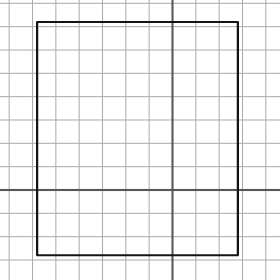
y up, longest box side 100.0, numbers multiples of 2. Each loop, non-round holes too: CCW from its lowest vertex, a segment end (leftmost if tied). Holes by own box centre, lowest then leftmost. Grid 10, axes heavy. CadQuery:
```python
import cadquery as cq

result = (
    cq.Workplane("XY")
    .moveTo(-58.0, -28.0)
    .lineTo(28.0, -28.0)
    .lineTo(28.0, 72.0)
    .lineTo(-58.0, 72.0)
    .close()
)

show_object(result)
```